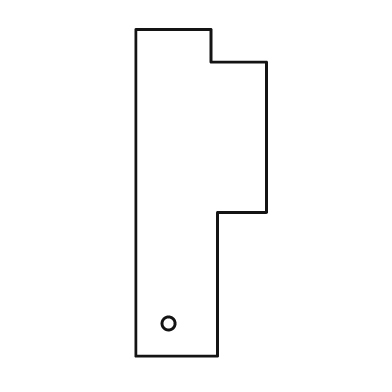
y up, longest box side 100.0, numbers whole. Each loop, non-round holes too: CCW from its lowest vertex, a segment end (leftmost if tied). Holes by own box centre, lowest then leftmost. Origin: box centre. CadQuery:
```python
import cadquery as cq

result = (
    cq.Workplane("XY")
    .moveTo(-20.0, -50.0)
    .lineTo(5.0, -50.0)
    .lineTo(5.0, -6.0)
    .lineTo(20.0, -6.0)
    .lineTo(20.0, 40.0)
    .lineTo(3.0, 40.0)
    .lineTo(3.0, 50.0)
    .lineTo(-20.0, 50.0)
    .close()
    .moveTo(-10.0, -40.0)
    .circle(2.0)
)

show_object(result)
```